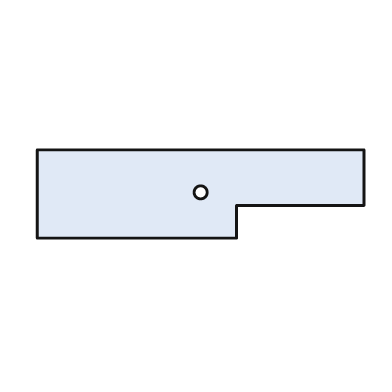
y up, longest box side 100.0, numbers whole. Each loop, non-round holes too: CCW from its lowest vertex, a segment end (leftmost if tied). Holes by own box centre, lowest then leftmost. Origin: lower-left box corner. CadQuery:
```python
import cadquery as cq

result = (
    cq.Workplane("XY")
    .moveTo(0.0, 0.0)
    .lineTo(61.0, 0.0)
    .lineTo(61.0, 10.0)
    .lineTo(100.0, 10.0)
    .lineTo(100.0, 27.0)
    .lineTo(0.0, 27.0)
    .close()
    .moveTo(50.0, 14.0)
    .circle(2.0)
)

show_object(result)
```